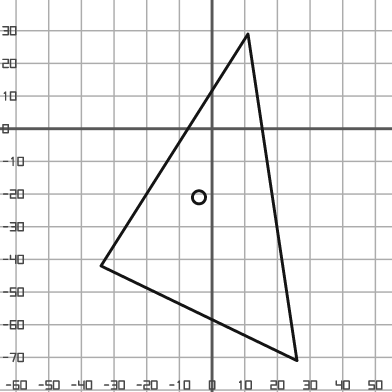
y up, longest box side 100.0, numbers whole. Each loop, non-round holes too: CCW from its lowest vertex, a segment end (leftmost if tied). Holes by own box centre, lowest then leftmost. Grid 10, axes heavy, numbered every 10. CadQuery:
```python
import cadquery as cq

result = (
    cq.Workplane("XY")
    .moveTo(26.0, -71.0)
    .lineTo(11.0, 29.0)
    .lineTo(-34.0, -42.0)
    .close()
    .moveTo(-4.0, -21.0)
    .circle(2.0)
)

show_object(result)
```